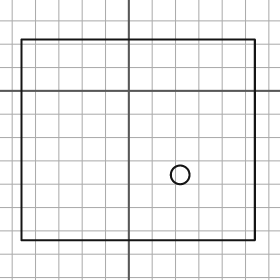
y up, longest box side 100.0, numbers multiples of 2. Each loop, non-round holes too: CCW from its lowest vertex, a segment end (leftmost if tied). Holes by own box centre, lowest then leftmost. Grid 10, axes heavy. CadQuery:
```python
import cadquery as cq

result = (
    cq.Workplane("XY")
    .moveTo(-46.0, -64.0)
    .lineTo(54.0, -64.0)
    .lineTo(54.0, 22.0)
    .lineTo(-46.0, 22.0)
    .close()
    .moveTo(22.0, -36.0)
    .circle(4.0)
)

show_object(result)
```